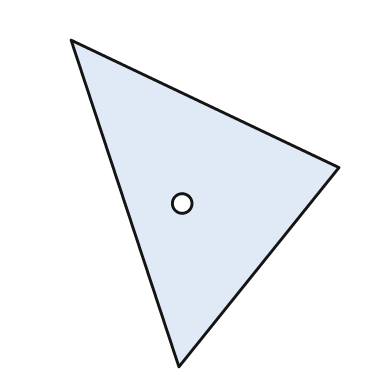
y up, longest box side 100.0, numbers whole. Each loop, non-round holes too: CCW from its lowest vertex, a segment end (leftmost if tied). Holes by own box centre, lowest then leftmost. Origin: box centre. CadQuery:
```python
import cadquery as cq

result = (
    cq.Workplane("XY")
    .moveTo(-8.0, -50.0)
    .lineTo(41.0, 11.0)
    .lineTo(-41.0, 50.0)
    .close()
    .moveTo(-7.0, 0.0)
    .circle(3.0)
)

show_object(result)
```